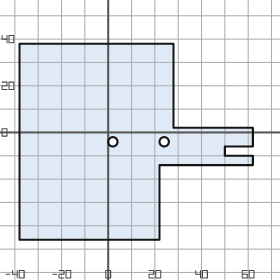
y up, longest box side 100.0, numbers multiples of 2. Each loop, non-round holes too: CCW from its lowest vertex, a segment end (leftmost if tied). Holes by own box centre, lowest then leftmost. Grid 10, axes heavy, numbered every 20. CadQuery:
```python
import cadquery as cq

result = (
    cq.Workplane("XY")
    .moveTo(-38.0, -46.0)
    .lineTo(22.0, -46.0)
    .lineTo(22.0, -14.0)
    .lineTo(62.0, -14.0)
    .lineTo(62.0, -10.0)
    .lineTo(50.0, -10.0)
    .lineTo(50.0, -6.0)
    .lineTo(62.0, -6.0)
    .lineTo(62.0, 2.0)
    .lineTo(28.0, 2.0)
    .lineTo(28.0, 38.0)
    .lineTo(-38.0, 38.0)
    .close()
    .moveTo(2.0, -4.0)
    .circle(2.0)
    .moveTo(24.0, -4.0)
    .circle(2.0)
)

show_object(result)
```